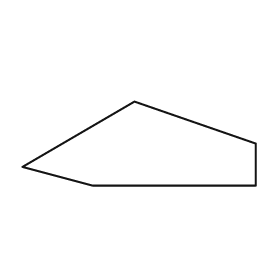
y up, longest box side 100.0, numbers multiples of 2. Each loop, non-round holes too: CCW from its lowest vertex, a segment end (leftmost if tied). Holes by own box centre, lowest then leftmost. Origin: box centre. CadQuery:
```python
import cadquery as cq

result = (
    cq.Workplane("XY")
    .moveTo(-20.0, -18.0)
    .lineTo(50.0, -18.0)
    .lineTo(50.0, 0.0)
    .lineTo(-2.0, 18.0)
    .lineTo(-50.0, -10.0)
    .close()
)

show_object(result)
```